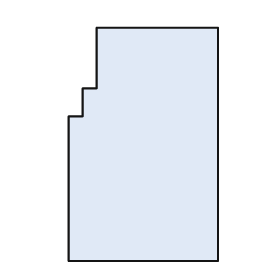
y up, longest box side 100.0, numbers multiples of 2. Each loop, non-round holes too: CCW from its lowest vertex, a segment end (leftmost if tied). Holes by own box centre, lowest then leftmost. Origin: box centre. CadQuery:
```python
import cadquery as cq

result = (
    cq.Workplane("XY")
    .moveTo(-32.0, -50.0)
    .lineTo(32.0, -50.0)
    .lineTo(32.0, 50.0)
    .lineTo(-20.0, 50.0)
    .lineTo(-20.0, 24.0)
    .lineTo(-26.0, 24.0)
    .lineTo(-26.0, 12.0)
    .lineTo(-32.0, 12.0)
    .close()
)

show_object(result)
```